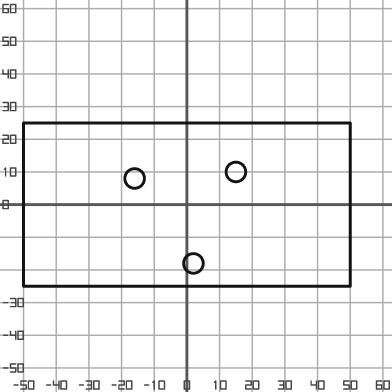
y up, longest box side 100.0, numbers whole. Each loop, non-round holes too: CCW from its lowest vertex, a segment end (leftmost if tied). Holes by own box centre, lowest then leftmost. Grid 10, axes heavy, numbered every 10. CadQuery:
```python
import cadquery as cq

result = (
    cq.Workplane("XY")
    .moveTo(-50.0, -25.0)
    .lineTo(50.0, -25.0)
    .lineTo(50.0, 25.0)
    .lineTo(-50.0, 25.0)
    .close()
    .moveTo(2.0, -18.0)
    .circle(3.0)
    .moveTo(-16.0, 8.0)
    .circle(3.0)
    .moveTo(15.0, 10.0)
    .circle(3.0)
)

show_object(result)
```